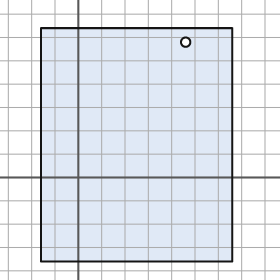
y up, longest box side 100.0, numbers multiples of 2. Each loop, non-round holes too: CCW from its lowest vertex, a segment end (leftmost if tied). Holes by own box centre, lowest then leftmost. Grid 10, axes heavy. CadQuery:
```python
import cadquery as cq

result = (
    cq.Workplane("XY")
    .moveTo(-16.0, -36.0)
    .lineTo(66.0, -36.0)
    .lineTo(66.0, 64.0)
    .lineTo(-16.0, 64.0)
    .close()
    .moveTo(46.0, 58.0)
    .circle(2.0)
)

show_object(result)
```